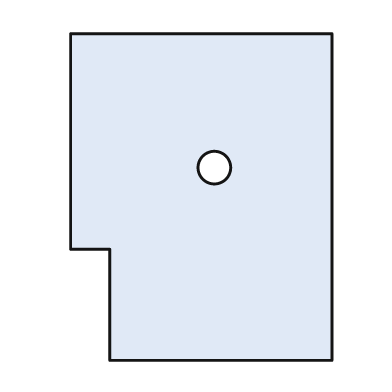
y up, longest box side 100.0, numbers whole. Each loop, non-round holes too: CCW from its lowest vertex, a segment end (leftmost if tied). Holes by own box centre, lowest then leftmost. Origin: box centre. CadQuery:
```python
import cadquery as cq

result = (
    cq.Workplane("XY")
    .moveTo(-28.0, -50.0)
    .lineTo(40.0, -50.0)
    .lineTo(40.0, 50.0)
    .lineTo(-40.0, 50.0)
    .lineTo(-40.0, -16.0)
    .lineTo(-28.0, -16.0)
    .close()
    .moveTo(4.0, 9.0)
    .circle(5.0)
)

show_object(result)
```